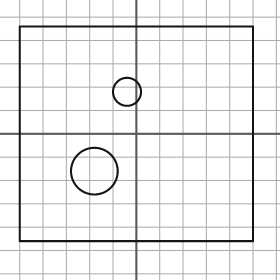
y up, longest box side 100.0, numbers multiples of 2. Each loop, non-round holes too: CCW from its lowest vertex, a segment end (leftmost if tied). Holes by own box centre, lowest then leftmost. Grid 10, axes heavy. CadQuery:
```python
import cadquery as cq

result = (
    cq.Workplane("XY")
    .moveTo(-50.0, -46.0)
    .lineTo(50.0, -46.0)
    .lineTo(50.0, 46.0)
    .lineTo(-50.0, 46.0)
    .close()
    .moveTo(-18.0, -16.0)
    .circle(10.0)
    .moveTo(-4.0, 18.0)
    .circle(6.0)
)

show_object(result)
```